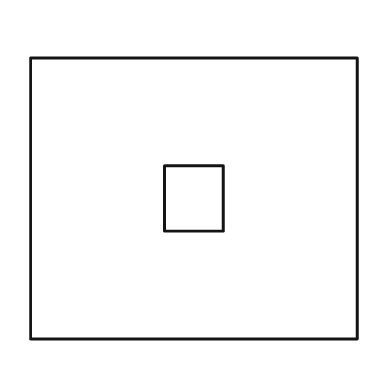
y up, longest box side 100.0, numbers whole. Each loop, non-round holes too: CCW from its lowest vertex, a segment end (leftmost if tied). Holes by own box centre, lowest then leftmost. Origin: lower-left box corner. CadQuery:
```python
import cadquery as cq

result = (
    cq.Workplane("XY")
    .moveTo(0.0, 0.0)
    .lineTo(100.0, 0.0)
    .lineTo(100.0, 86.0)
    .lineTo(0.0, 86.0)
    .close()
    .moveTo(41.0, 33.0)
    .lineTo(59.0, 33.0)
    .lineTo(59.0, 53.0)
    .lineTo(41.0, 53.0)
    .close()
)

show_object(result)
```